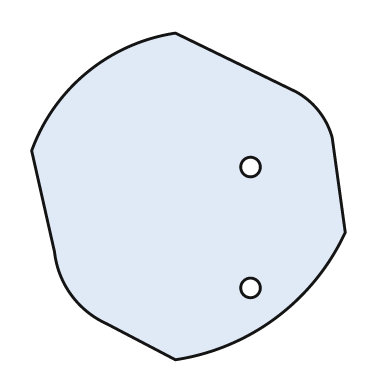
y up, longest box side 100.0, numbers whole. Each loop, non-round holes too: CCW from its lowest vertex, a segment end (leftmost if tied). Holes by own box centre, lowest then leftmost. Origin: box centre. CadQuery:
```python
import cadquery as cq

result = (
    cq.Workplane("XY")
    .moveTo(-4.0, -50.0)
    .threePointArc((27.0, -37.0), (48.0, -11.0))
    .lineTo(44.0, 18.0)
    .threePointArc((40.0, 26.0), (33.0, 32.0))
    .lineTo(-4.0, 50.0)
    .threePointArc((-31.0, 38.0), (-48.0, 14.0))
    .lineTo(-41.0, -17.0)
    .threePointArc((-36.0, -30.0), (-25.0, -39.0))
    .close()
    .moveTo(19.0, -28.0)
    .circle(3.0)
    .moveTo(19.0, 9.0)
    .circle(3.0)
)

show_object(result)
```